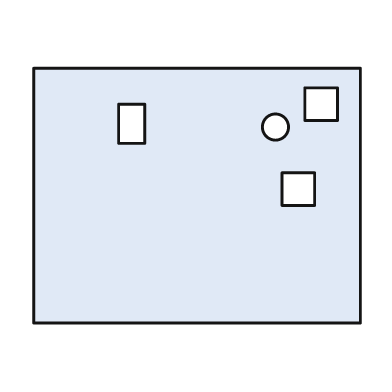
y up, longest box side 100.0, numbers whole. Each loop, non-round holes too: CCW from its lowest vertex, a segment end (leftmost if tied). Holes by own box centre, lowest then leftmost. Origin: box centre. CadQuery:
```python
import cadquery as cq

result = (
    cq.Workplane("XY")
    .moveTo(-50.0, -39.0)
    .lineTo(50.0, -39.0)
    .lineTo(50.0, 39.0)
    .lineTo(-50.0, 39.0)
    .close()
    .moveTo(26.0, -3.0)
    .lineTo(36.0, -3.0)
    .lineTo(36.0, 7.0)
    .lineTo(26.0, 7.0)
    .close()
    .moveTo(24.0, 21.0)
    .circle(4.0)
    .moveTo(-24.0, 16.0)
    .lineTo(-16.0, 16.0)
    .lineTo(-16.0, 28.0)
    .lineTo(-24.0, 28.0)
    .close()
    .moveTo(33.0, 23.0)
    .lineTo(43.0, 23.0)
    .lineTo(43.0, 33.0)
    .lineTo(33.0, 33.0)
    .close()
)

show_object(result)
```